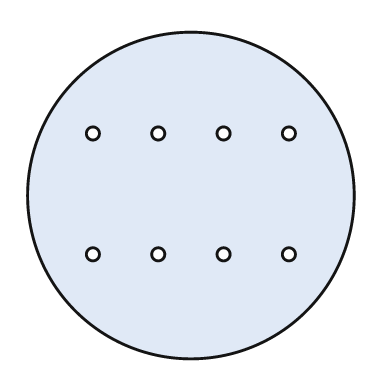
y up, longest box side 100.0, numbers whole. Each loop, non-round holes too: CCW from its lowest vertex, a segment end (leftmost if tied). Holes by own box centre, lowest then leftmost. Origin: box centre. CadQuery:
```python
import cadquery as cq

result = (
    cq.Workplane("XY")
    .moveTo(0.0, 0.0)
    .circle(50.0)
    .moveTo(-30.0, -18.0)
    .circle(2.0)
    .moveTo(-10.0, -18.0)
    .circle(2.0)
    .moveTo(10.0, -18.0)
    .circle(2.0)
    .moveTo(30.0, -18.0)
    .circle(2.0)
    .moveTo(-30.0, 19.0)
    .circle(2.0)
    .moveTo(-10.0, 19.0)
    .circle(2.0)
    .moveTo(10.0, 19.0)
    .circle(2.0)
    .moveTo(30.0, 19.0)
    .circle(2.0)
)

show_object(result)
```